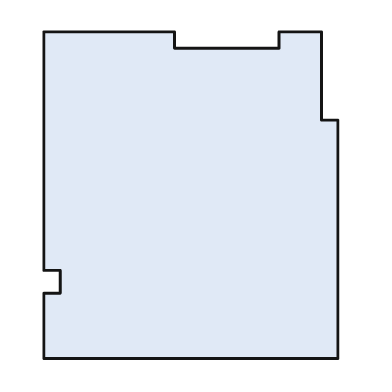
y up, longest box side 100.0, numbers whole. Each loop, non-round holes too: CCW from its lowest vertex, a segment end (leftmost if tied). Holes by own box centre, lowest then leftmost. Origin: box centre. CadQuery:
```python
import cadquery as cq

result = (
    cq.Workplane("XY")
    .moveTo(-45.0, -50.0)
    .lineTo(45.0, -50.0)
    .lineTo(45.0, 23.0)
    .lineTo(40.0, 23.0)
    .lineTo(40.0, 50.0)
    .lineTo(27.0, 50.0)
    .lineTo(27.0, 45.0)
    .lineTo(-5.0, 45.0)
    .lineTo(-5.0, 50.0)
    .lineTo(-45.0, 50.0)
    .lineTo(-45.0, -23.0)
    .lineTo(-40.0, -23.0)
    .lineTo(-40.0, -30.0)
    .lineTo(-45.0, -30.0)
    .close()
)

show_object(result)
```